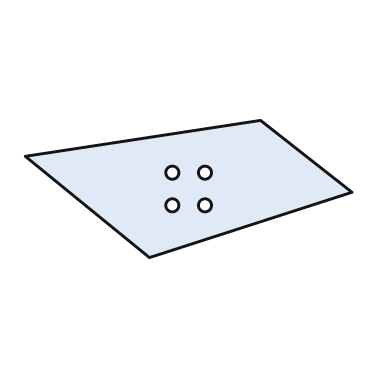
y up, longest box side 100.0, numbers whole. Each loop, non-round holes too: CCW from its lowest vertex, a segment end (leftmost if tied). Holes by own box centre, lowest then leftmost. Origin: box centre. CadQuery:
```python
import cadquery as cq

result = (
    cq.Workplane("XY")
    .moveTo(-12.0, -21.0)
    .lineTo(50.0, -1.0)
    .lineTo(22.0, 21.0)
    .lineTo(-50.0, 10.0)
    .close()
    .moveTo(-5.0, -5.0)
    .circle(2.0)
    .moveTo(5.0, -5.0)
    .circle(2.0)
    .moveTo(-5.0, 5.0)
    .circle(2.0)
    .moveTo(5.0, 5.0)
    .circle(2.0)
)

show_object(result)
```